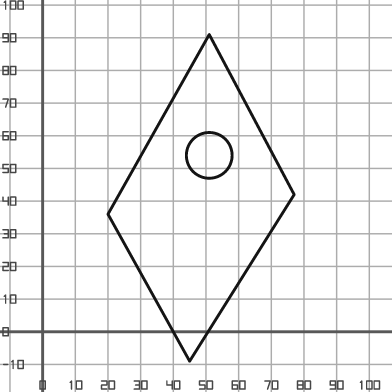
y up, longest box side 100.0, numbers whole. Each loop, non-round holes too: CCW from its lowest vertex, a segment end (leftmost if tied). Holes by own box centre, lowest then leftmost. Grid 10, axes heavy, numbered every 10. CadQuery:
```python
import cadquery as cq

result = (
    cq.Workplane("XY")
    .moveTo(45.0, -9.0)
    .lineTo(77.0, 42.0)
    .lineTo(51.0, 91.0)
    .lineTo(20.0, 36.0)
    .close()
    .moveTo(51.0, 54.0)
    .circle(7.0)
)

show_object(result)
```